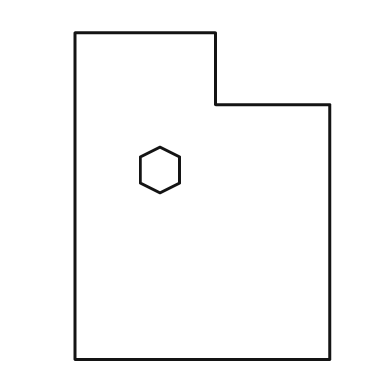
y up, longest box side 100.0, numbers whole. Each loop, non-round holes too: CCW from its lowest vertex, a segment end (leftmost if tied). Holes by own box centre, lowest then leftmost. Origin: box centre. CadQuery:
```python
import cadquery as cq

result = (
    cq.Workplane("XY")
    .moveTo(-39.0, -50.0)
    .lineTo(39.0, -50.0)
    .lineTo(39.0, 28.0)
    .lineTo(4.0, 28.0)
    .lineTo(4.0, 50.0)
    .lineTo(-39.0, 50.0)
    .close()
    .moveTo(-13.0, 1.0)
    .lineTo(-7.0, 4.0)
    .lineTo(-7.0, 12.0)
    .lineTo(-13.0, 15.0)
    .lineTo(-19.0, 12.0)
    .lineTo(-19.0, 4.0)
    .close()
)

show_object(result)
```